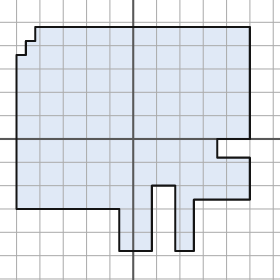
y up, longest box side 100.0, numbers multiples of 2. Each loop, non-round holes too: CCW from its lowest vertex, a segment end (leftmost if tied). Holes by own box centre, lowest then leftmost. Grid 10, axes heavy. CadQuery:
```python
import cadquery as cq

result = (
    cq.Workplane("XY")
    .moveTo(-6.0, -48.0)
    .lineTo(8.0, -48.0)
    .lineTo(8.0, -20.0)
    .lineTo(18.0, -20.0)
    .lineTo(18.0, -48.0)
    .lineTo(26.0, -48.0)
    .lineTo(26.0, -26.0)
    .lineTo(50.0, -26.0)
    .lineTo(50.0, -8.0)
    .lineTo(36.0, -8.0)
    .lineTo(36.0, 0.0)
    .lineTo(50.0, 0.0)
    .lineTo(50.0, 48.0)
    .lineTo(-42.0, 48.0)
    .lineTo(-42.0, 42.0)
    .lineTo(-46.0, 42.0)
    .lineTo(-46.0, 36.0)
    .lineTo(-50.0, 36.0)
    .lineTo(-50.0, -30.0)
    .lineTo(-6.0, -30.0)
    .close()
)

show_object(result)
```